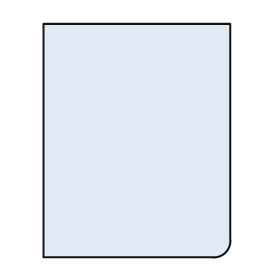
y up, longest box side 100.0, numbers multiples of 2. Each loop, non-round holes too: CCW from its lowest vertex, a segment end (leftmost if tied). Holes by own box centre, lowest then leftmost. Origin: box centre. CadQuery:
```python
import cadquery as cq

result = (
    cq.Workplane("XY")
    .moveTo(-40.0, -50.0)
    .lineTo(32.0, -50.0)
    .threePointArc((38.0, -48.0), (40.0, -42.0))
    .lineTo(40.0, 50.0)
    .lineTo(-40.0, 50.0)
    .close()
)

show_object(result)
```